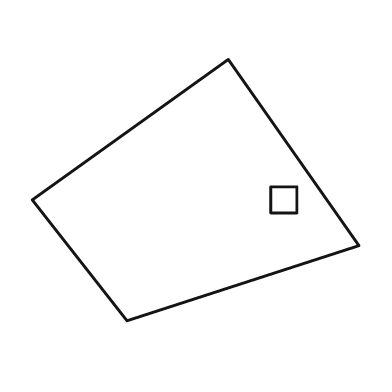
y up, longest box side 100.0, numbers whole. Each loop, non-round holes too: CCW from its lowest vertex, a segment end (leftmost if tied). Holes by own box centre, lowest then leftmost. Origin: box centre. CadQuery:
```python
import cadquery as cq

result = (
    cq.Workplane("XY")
    .moveTo(-21.0, -40.0)
    .lineTo(50.0, -17.0)
    .lineTo(10.0, 40.0)
    .lineTo(-50.0, -3.0)
    .close()
    .moveTo(23.0, -7.0)
    .lineTo(31.0, -7.0)
    .lineTo(31.0, 1.0)
    .lineTo(23.0, 1.0)
    .close()
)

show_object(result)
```